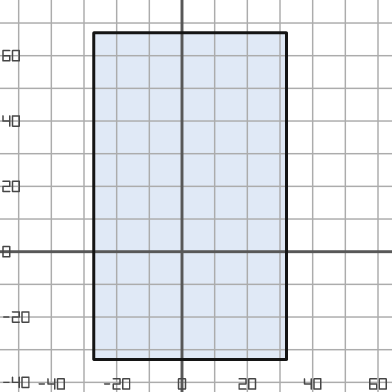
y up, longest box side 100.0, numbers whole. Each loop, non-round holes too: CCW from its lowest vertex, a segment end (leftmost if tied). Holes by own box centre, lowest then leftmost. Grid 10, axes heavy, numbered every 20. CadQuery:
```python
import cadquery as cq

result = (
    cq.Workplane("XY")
    .moveTo(-27.0, -33.0)
    .lineTo(32.0, -33.0)
    .lineTo(32.0, 67.0)
    .lineTo(-27.0, 67.0)
    .close()
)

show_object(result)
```